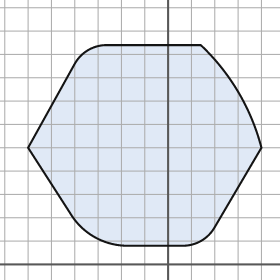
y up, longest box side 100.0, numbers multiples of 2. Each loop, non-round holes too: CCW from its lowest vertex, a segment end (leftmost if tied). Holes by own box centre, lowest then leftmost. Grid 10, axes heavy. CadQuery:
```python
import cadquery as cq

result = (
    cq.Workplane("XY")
    .moveTo(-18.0, 8.0)
    .lineTo(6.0, 8.0)
    .threePointArc((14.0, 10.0), (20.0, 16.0))
    .lineTo(40.0, 50.0)
    .threePointArc((30.0, 74.0), (14.0, 94.0))
    .lineTo(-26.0, 94.0)
    .threePointArc((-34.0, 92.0), (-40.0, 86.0))
    .lineTo(-60.0, 50.0)
    .lineTo(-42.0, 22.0)
    .threePointArc((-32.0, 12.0), (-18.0, 8.0))
    .close()
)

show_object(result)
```